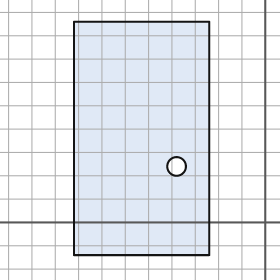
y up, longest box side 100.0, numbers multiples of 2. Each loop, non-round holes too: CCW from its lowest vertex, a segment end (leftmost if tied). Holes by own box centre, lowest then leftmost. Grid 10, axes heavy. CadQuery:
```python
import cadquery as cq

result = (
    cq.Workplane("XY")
    .moveTo(-82.0, -14.0)
    .lineTo(-24.0, -14.0)
    .lineTo(-24.0, 86.0)
    .lineTo(-82.0, 86.0)
    .close()
    .moveTo(-38.0, 24.0)
    .circle(4.0)
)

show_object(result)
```